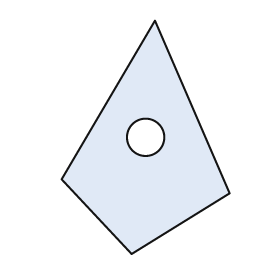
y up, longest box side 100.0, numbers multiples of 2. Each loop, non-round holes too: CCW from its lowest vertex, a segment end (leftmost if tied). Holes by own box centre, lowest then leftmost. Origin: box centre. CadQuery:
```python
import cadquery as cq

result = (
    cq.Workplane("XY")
    .moveTo(-6.0, -50.0)
    .lineTo(36.0, -24.0)
    .lineTo(4.0, 50.0)
    .lineTo(-36.0, -18.0)
    .close()
    .moveTo(0.0, 0.0)
    .circle(8.0)
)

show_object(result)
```